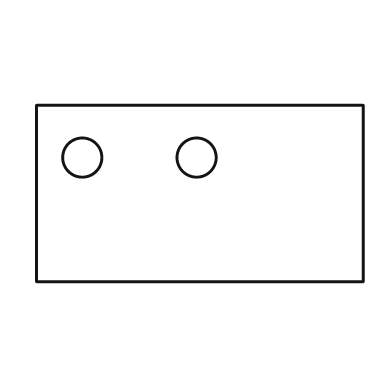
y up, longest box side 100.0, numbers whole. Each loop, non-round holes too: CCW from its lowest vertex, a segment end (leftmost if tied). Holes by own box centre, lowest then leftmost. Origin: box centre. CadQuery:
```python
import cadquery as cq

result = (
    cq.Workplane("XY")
    .moveTo(-50.0, -27.0)
    .lineTo(50.0, -27.0)
    .lineTo(50.0, 27.0)
    .lineTo(-50.0, 27.0)
    .close()
    .moveTo(-36.0, 11.0)
    .circle(6.0)
    .moveTo(-1.0, 11.0)
    .circle(6.0)
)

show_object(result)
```